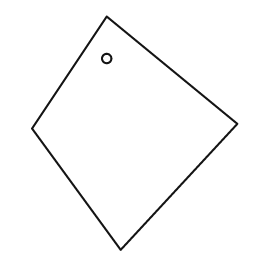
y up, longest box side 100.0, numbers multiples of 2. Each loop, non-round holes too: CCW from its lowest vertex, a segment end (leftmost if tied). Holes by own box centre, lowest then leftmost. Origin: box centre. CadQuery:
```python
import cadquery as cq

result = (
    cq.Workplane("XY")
    .moveTo(-6.0, -50.0)
    .lineTo(44.0, 4.0)
    .lineTo(-12.0, 50.0)
    .lineTo(-44.0, 2.0)
    .close()
    .moveTo(-12.0, 32.0)
    .circle(2.0)
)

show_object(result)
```